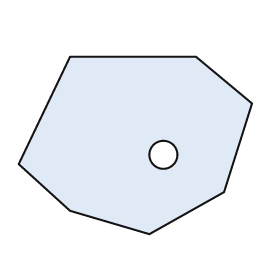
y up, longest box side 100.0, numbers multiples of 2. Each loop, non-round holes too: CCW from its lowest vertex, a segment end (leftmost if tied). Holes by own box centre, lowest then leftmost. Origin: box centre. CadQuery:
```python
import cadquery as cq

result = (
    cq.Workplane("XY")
    .moveTo(6.0, -38.0)
    .lineTo(38.0, -20.0)
    .lineTo(50.0, 18.0)
    .lineTo(26.0, 38.0)
    .lineTo(-28.0, 38.0)
    .lineTo(-50.0, -8.0)
    .lineTo(-28.0, -28.0)
    .close()
    .moveTo(12.0, -4.0)
    .circle(6.0)
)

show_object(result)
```